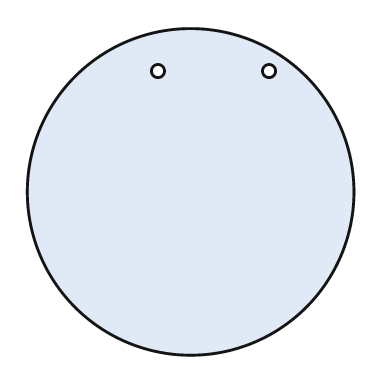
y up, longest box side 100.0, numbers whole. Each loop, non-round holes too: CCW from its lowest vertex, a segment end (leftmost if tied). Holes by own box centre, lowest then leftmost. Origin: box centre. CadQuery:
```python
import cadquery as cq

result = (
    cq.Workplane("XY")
    .moveTo(0.0, 0.0)
    .circle(50.0)
    .moveTo(-10.0, 37.0)
    .circle(2.0)
    .moveTo(24.0, 37.0)
    .circle(2.0)
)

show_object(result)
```